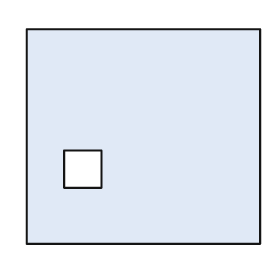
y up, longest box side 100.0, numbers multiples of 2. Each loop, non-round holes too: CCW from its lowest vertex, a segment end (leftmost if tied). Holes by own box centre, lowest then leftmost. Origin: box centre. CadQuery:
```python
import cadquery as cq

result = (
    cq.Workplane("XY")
    .moveTo(-50.0, -46.0)
    .lineTo(50.0, -46.0)
    .lineTo(50.0, 46.0)
    .lineTo(-50.0, 46.0)
    .close()
    .moveTo(-34.0, -22.0)
    .lineTo(-18.0, -22.0)
    .lineTo(-18.0, -6.0)
    .lineTo(-34.0, -6.0)
    .close()
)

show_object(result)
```